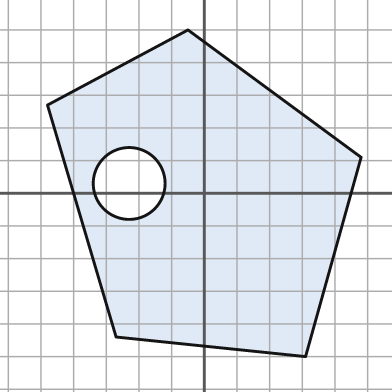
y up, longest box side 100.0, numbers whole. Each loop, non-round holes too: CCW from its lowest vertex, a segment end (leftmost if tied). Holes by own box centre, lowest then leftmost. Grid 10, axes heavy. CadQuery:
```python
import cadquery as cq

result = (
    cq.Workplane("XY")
    .moveTo(31.0, -50.0)
    .lineTo(48.0, 11.0)
    .lineTo(-5.0, 50.0)
    .lineTo(-48.0, 27.0)
    .lineTo(-27.0, -44.0)
    .close()
    .moveTo(-23.0, 3.0)
    .circle(11.0)
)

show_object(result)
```